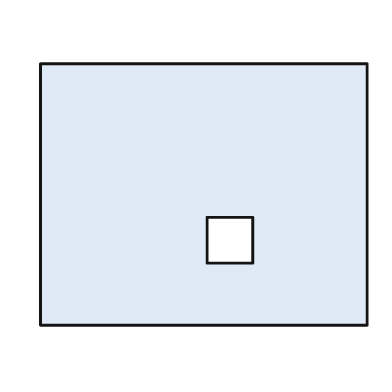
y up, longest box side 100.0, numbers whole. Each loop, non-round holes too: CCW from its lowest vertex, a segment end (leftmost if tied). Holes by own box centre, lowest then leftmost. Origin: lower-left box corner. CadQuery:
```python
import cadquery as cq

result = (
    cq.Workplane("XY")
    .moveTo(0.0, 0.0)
    .lineTo(100.0, 0.0)
    .lineTo(100.0, 80.0)
    .lineTo(0.0, 80.0)
    .close()
    .moveTo(51.0, 19.0)
    .lineTo(65.0, 19.0)
    .lineTo(65.0, 33.0)
    .lineTo(51.0, 33.0)
    .close()
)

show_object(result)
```